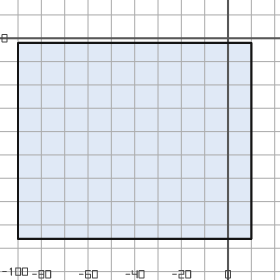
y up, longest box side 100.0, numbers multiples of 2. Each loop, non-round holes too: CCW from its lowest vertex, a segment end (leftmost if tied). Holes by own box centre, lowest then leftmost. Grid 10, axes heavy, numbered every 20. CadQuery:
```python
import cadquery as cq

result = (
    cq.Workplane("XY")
    .moveTo(-90.0, -86.0)
    .lineTo(10.0, -86.0)
    .lineTo(10.0, -2.0)
    .lineTo(-90.0, -2.0)
    .close()
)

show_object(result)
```